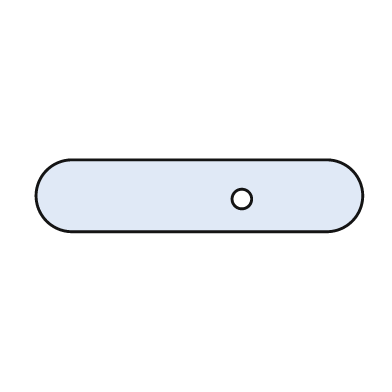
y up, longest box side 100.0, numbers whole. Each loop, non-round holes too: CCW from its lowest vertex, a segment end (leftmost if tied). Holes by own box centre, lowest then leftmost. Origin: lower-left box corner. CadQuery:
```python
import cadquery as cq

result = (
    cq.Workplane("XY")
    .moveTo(11.0, 0.0)
    .lineTo(89.0, 0.0)
    .threePointArc((100.0, 11.0), (89.0, 22.0))
    .lineTo(11.0, 22.0)
    .threePointArc((0.0, 11.0), (11.0, 0.0))
    .close()
    .moveTo(63.0, 10.0)
    .circle(3.0)
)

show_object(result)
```